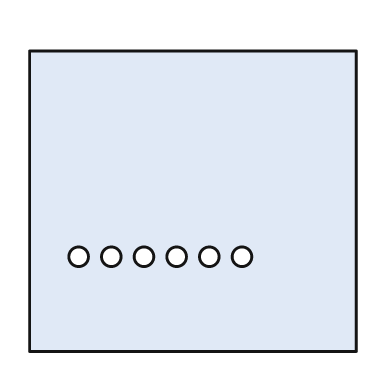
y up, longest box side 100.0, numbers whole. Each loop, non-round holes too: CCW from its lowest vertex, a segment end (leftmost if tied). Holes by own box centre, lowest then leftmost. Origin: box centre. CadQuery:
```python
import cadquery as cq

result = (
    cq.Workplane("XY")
    .moveTo(-50.0, -46.0)
    .lineTo(50.0, -46.0)
    .lineTo(50.0, 46.0)
    .lineTo(-50.0, 46.0)
    .close()
    .moveTo(-35.0, -17.0)
    .circle(3.0)
    .moveTo(-25.0, -17.0)
    .circle(3.0)
    .moveTo(-15.0, -17.0)
    .circle(3.0)
    .moveTo(-5.0, -17.0)
    .circle(3.0)
    .moveTo(5.0, -17.0)
    .circle(3.0)
    .moveTo(15.0, -17.0)
    .circle(3.0)
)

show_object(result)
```